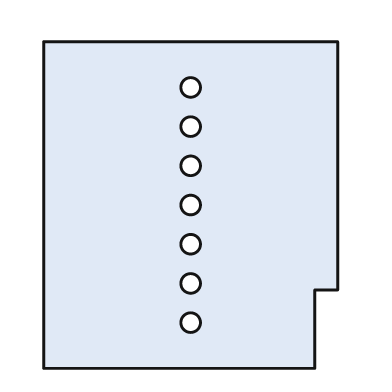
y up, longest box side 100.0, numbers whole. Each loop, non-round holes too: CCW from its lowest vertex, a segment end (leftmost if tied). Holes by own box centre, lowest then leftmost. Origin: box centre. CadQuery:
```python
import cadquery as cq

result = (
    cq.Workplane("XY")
    .moveTo(-45.0, -50.0)
    .lineTo(38.0, -50.0)
    .lineTo(38.0, -26.0)
    .lineTo(45.0, -26.0)
    .lineTo(45.0, 50.0)
    .lineTo(-45.0, 50.0)
    .close()
    .moveTo(0.0, -36.0)
    .circle(3.0)
    .moveTo(0.0, -24.0)
    .circle(3.0)
    .moveTo(0.0, -12.0)
    .circle(3.0)
    .moveTo(0.0, 0.0)
    .circle(3.0)
    .moveTo(0.0, 12.0)
    .circle(3.0)
    .moveTo(0.0, 24.0)
    .circle(3.0)
    .moveTo(0.0, 36.0)
    .circle(3.0)
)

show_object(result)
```